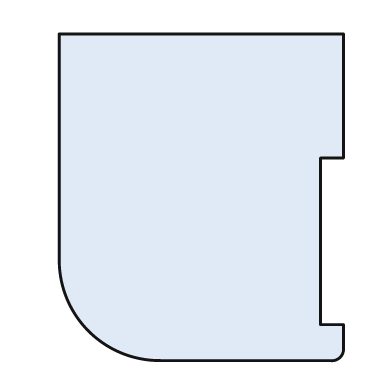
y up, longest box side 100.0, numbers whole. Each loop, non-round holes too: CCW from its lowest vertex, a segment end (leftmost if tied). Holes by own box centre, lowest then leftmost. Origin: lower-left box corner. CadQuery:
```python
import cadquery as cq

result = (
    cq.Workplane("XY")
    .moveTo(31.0, 0.0)
    .lineTo(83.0, 0.0)
    .threePointArc((86.0, 1.0), (87.0, 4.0))
    .lineTo(87.0, 11.0)
    .lineTo(80.0, 11.0)
    .lineTo(80.0, 62.0)
    .lineTo(87.0, 62.0)
    .lineTo(87.0, 100.0)
    .lineTo(0.0, 100.0)
    .lineTo(0.0, 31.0)
    .threePointArc((9.0, 9.0), (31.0, 0.0))
    .close()
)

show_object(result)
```